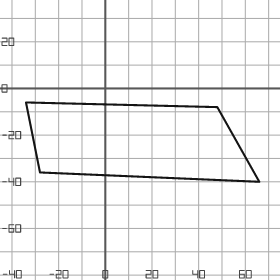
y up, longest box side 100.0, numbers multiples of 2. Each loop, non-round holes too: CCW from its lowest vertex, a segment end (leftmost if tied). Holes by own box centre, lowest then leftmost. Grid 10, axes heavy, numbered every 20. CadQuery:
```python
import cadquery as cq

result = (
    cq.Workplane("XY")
    .moveTo(66.0, -40.0)
    .lineTo(48.0, -8.0)
    .lineTo(-34.0, -6.0)
    .lineTo(-28.0, -36.0)
    .close()
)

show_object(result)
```